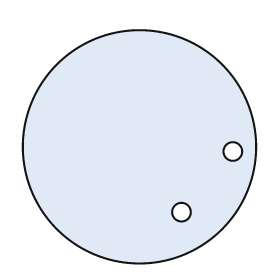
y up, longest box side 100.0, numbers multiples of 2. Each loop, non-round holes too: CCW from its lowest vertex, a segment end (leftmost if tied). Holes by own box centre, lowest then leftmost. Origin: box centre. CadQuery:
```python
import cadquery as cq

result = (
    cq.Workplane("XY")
    .moveTo(0.0, 0.0)
    .circle(50.0)
    .moveTo(18.0, -28.0)
    .circle(4.0)
    .moveTo(40.0, -2.0)
    .circle(4.0)
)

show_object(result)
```